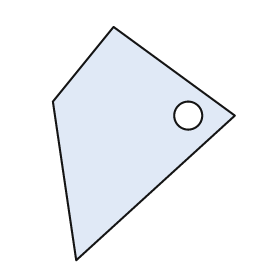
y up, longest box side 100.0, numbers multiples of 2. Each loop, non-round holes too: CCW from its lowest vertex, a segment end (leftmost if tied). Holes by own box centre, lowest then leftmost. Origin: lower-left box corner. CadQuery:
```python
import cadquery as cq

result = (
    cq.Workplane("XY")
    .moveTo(10.0, 0.0)
    .lineTo(78.0, 62.0)
    .lineTo(26.0, 100.0)
    .lineTo(0.0, 68.0)
    .close()
    .moveTo(58.0, 62.0)
    .circle(6.0)
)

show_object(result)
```